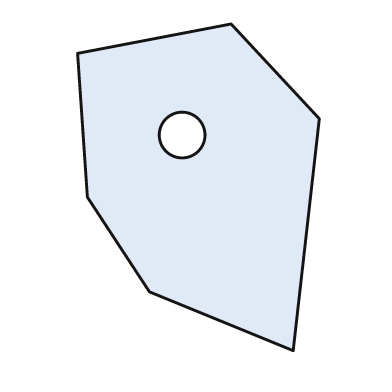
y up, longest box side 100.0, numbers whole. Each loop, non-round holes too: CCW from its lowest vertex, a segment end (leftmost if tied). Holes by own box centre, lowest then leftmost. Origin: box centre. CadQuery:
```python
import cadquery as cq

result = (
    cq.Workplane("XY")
    .moveTo(29.0, -50.0)
    .lineTo(37.0, 21.0)
    .lineTo(10.0, 50.0)
    .lineTo(-37.0, 41.0)
    .lineTo(-34.0, -3.0)
    .lineTo(-15.0, -32.0)
    .close()
    .moveTo(-5.0, 16.0)
    .circle(7.0)
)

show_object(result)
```